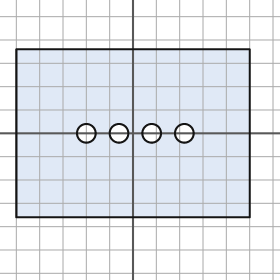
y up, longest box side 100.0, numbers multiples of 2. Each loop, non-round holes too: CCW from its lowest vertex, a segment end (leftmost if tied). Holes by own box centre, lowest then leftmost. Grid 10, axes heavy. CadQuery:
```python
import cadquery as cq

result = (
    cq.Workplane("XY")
    .moveTo(-50.0, -36.0)
    .lineTo(50.0, -36.0)
    .lineTo(50.0, 36.0)
    .lineTo(-50.0, 36.0)
    .close()
    .moveTo(-20.0, 0.0)
    .circle(4.0)
    .moveTo(-6.0, 0.0)
    .circle(4.0)
    .moveTo(8.0, 0.0)
    .circle(4.0)
    .moveTo(22.0, 0.0)
    .circle(4.0)
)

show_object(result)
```